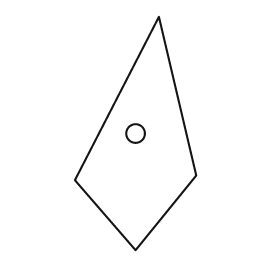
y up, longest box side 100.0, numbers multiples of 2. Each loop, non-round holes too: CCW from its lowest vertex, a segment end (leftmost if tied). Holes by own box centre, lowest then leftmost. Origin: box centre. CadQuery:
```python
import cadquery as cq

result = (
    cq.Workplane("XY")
    .moveTo(0.0, -50.0)
    .lineTo(26.0, -18.0)
    .lineTo(10.0, 50.0)
    .lineTo(-26.0, -20.0)
    .close()
    .moveTo(0.0, 0.0)
    .circle(4.0)
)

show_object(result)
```